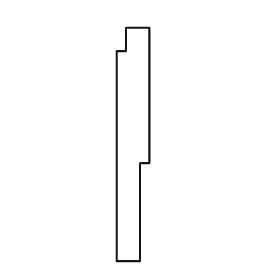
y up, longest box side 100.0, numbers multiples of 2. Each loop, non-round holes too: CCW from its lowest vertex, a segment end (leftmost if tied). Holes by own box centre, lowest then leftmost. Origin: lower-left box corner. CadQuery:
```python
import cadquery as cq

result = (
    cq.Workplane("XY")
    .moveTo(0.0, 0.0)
    .lineTo(10.0, 0.0)
    .lineTo(10.0, 42.0)
    .lineTo(14.0, 42.0)
    .lineTo(14.0, 100.0)
    .lineTo(4.0, 100.0)
    .lineTo(4.0, 90.0)
    .lineTo(0.0, 90.0)
    .close()
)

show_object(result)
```